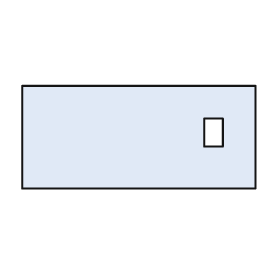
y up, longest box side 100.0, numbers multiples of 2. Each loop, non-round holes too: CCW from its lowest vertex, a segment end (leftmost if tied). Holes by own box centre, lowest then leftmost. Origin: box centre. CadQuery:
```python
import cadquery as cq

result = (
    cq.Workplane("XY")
    .moveTo(-50.0, -22.0)
    .lineTo(50.0, -22.0)
    .lineTo(50.0, 22.0)
    .lineTo(-50.0, 22.0)
    .close()
    .moveTo(28.0, -4.0)
    .lineTo(36.0, -4.0)
    .lineTo(36.0, 8.0)
    .lineTo(28.0, 8.0)
    .close()
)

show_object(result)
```